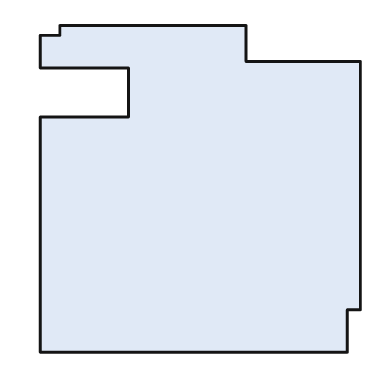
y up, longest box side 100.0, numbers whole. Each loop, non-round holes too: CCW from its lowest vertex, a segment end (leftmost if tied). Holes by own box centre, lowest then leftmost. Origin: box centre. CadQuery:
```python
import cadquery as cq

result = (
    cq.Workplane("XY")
    .moveTo(-49.0, -50.0)
    .lineTo(45.0, -50.0)
    .lineTo(45.0, -37.0)
    .lineTo(49.0, -37.0)
    .lineTo(49.0, 39.0)
    .lineTo(14.0, 39.0)
    .lineTo(14.0, 50.0)
    .lineTo(-43.0, 50.0)
    .lineTo(-43.0, 47.0)
    .lineTo(-49.0, 47.0)
    .lineTo(-49.0, 37.0)
    .lineTo(-22.0, 37.0)
    .lineTo(-22.0, 22.0)
    .lineTo(-49.0, 22.0)
    .close()
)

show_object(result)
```